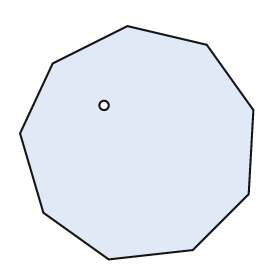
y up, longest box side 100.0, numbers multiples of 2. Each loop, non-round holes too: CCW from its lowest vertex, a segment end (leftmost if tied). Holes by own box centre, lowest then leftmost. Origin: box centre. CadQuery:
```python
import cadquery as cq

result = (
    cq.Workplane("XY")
    .moveTo(-12.0, -50.0)
    .lineTo(24.0, -46.0)
    .lineTo(48.0, -22.0)
    .lineTo(50.0, 14.0)
    .lineTo(30.0, 42.0)
    .lineTo(-4.0, 50.0)
    .lineTo(-36.0, 34.0)
    .lineTo(-50.0, 4.0)
    .lineTo(-40.0, -30.0)
    .close()
    .moveTo(-14.0, 16.0)
    .circle(2.0)
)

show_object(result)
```